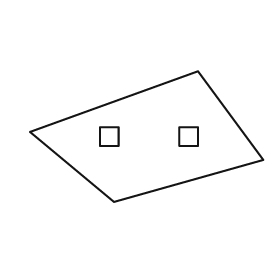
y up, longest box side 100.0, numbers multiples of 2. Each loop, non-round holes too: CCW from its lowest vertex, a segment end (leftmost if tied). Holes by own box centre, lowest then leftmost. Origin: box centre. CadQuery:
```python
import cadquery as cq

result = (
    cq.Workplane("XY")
    .moveTo(-14.0, -28.0)
    .lineTo(50.0, -10.0)
    .lineTo(22.0, 28.0)
    .lineTo(-50.0, 2.0)
    .close()
    .moveTo(-20.0, -4.0)
    .lineTo(-12.0, -4.0)
    .lineTo(-12.0, 4.0)
    .lineTo(-20.0, 4.0)
    .close()
    .moveTo(14.0, -4.0)
    .lineTo(22.0, -4.0)
    .lineTo(22.0, 4.0)
    .lineTo(14.0, 4.0)
    .close()
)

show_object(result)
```